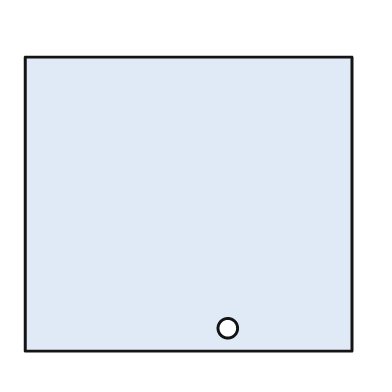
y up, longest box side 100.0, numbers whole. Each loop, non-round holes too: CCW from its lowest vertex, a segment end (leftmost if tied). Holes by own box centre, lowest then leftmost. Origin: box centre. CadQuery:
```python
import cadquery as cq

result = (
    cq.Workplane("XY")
    .moveTo(-50.0, -45.0)
    .lineTo(50.0, -45.0)
    .lineTo(50.0, 45.0)
    .lineTo(-50.0, 45.0)
    .close()
    .moveTo(12.0, -38.0)
    .circle(3.0)
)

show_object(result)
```